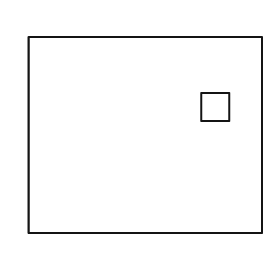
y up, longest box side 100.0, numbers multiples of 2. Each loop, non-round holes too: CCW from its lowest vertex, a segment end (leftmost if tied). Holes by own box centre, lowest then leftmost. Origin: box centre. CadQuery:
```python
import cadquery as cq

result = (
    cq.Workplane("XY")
    .moveTo(-50.0, -42.0)
    .lineTo(50.0, -42.0)
    .lineTo(50.0, 42.0)
    .lineTo(-50.0, 42.0)
    .close()
    .moveTo(24.0, 6.0)
    .lineTo(36.0, 6.0)
    .lineTo(36.0, 18.0)
    .lineTo(24.0, 18.0)
    .close()
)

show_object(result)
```